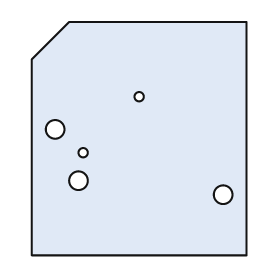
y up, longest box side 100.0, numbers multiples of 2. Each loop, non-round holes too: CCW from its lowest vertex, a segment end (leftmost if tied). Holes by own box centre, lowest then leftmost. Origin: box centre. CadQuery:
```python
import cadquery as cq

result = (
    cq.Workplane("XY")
    .moveTo(-46.0, -50.0)
    .lineTo(46.0, -50.0)
    .lineTo(46.0, 50.0)
    .lineTo(-30.0, 50.0)
    .lineTo(-46.0, 34.0)
    .close()
    .moveTo(36.0, -24.0)
    .circle(4.0)
    .moveTo(-26.0, -18.0)
    .circle(4.0)
    .moveTo(-24.0, -6.0)
    .circle(2.0)
    .moveTo(-36.0, 4.0)
    .circle(4.0)
    .moveTo(0.0, 18.0)
    .circle(2.0)
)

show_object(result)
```